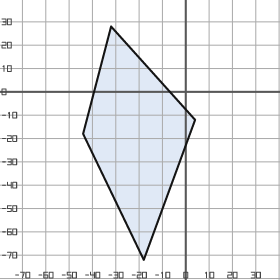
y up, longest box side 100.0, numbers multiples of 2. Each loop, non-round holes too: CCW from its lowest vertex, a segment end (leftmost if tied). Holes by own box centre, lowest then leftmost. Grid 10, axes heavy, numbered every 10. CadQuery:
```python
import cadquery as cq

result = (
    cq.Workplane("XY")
    .moveTo(-18.0, -72.0)
    .lineTo(4.0, -12.0)
    .lineTo(-32.0, 28.0)
    .lineTo(-44.0, -18.0)
    .close()
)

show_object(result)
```